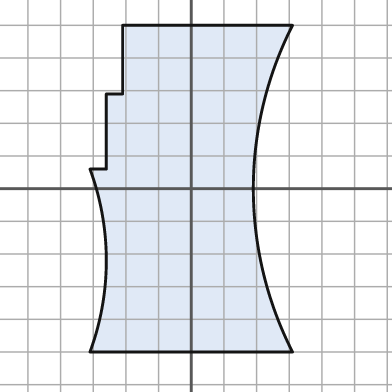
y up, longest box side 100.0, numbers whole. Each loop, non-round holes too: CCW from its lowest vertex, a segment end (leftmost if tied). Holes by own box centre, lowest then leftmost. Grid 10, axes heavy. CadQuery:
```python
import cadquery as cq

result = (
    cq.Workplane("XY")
    .moveTo(-31.0, -50.0)
    .lineTo(31.0, -50.0)
    .threePointArc((19.0, 0.0), (31.0, 50.0))
    .lineTo(-21.0, 50.0)
    .lineTo(-21.0, 29.0)
    .lineTo(-26.0, 29.0)
    .lineTo(-26.0, 6.0)
    .lineTo(-31.0, 6.0)
    .threePointArc((-26.0, -22.0), (-31.0, -50.0))
    .close()
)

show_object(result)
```